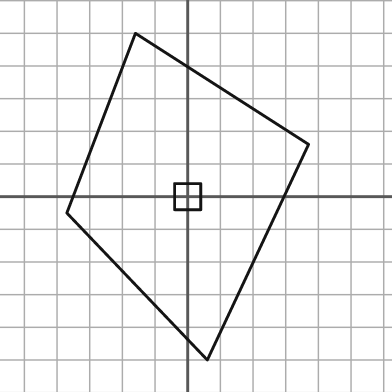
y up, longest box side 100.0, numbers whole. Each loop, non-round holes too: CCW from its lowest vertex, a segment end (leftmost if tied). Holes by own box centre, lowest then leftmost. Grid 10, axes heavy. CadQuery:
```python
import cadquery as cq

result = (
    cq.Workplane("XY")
    .moveTo(6.0, -50.0)
    .lineTo(37.0, 16.0)
    .lineTo(-16.0, 50.0)
    .lineTo(-37.0, -5.0)
    .close()
    .moveTo(-4.0, -4.0)
    .lineTo(4.0, -4.0)
    .lineTo(4.0, 4.0)
    .lineTo(-4.0, 4.0)
    .close()
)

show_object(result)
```